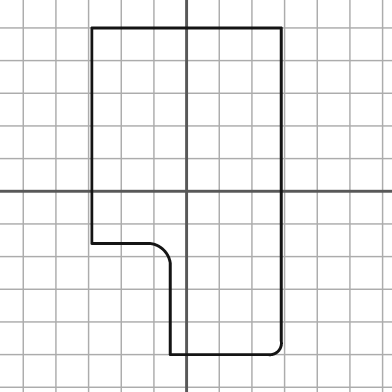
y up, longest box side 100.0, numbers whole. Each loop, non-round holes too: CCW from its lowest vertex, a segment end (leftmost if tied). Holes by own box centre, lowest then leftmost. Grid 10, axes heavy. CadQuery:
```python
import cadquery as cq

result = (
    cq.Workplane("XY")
    .moveTo(-5.0, -50.0)
    .lineTo(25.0, -50.0)
    .threePointArc((28.0, -49.0), (29.0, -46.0))
    .lineTo(29.0, 50.0)
    .lineTo(-29.0, 50.0)
    .lineTo(-29.0, -16.0)
    .lineTo(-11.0, -16.0)
    .threePointArc((-7.0, -18.0), (-5.0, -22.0))
    .close()
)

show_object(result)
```